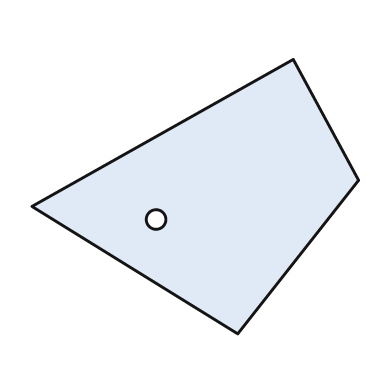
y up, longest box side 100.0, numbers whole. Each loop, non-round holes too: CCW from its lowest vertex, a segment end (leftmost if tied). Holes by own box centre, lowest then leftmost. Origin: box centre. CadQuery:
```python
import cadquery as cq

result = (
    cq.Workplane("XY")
    .moveTo(13.0, -42.0)
    .lineTo(50.0, 5.0)
    .lineTo(30.0, 42.0)
    .lineTo(-50.0, -3.0)
    .close()
    .moveTo(-12.0, -7.0)
    .circle(3.0)
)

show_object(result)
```